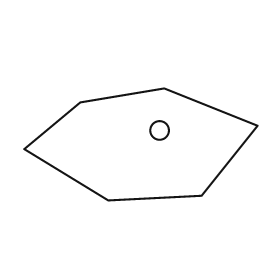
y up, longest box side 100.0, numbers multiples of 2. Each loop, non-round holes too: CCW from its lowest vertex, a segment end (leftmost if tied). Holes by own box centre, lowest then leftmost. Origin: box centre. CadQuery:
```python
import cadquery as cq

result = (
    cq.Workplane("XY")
    .moveTo(-14.0, -24.0)
    .lineTo(26.0, -22.0)
    .lineTo(50.0, 8.0)
    .lineTo(10.0, 24.0)
    .lineTo(-26.0, 18.0)
    .lineTo(-50.0, -2.0)
    .close()
    .moveTo(8.0, 6.0)
    .circle(4.0)
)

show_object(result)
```